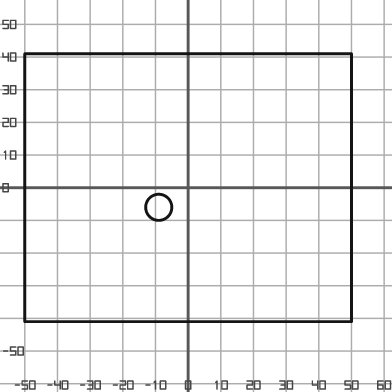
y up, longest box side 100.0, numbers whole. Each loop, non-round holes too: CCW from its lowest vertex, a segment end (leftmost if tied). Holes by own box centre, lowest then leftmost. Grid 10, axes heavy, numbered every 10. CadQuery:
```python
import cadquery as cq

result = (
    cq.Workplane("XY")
    .moveTo(-50.0, -41.0)
    .lineTo(50.0, -41.0)
    .lineTo(50.0, 41.0)
    .lineTo(-50.0, 41.0)
    .close()
    .moveTo(-9.0, -6.0)
    .circle(4.0)
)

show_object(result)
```